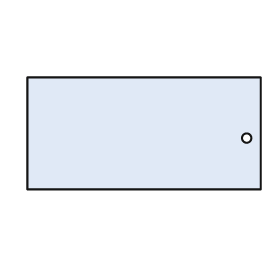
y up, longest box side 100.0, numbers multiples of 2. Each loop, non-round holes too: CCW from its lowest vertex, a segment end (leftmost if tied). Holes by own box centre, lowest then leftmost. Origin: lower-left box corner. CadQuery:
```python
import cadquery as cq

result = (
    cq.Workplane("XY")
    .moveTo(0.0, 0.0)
    .lineTo(100.0, 0.0)
    .lineTo(100.0, 48.0)
    .lineTo(0.0, 48.0)
    .close()
    .moveTo(94.0, 22.0)
    .circle(2.0)
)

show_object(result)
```